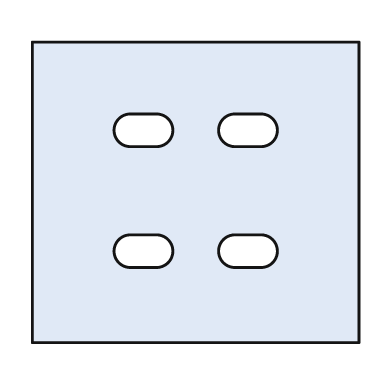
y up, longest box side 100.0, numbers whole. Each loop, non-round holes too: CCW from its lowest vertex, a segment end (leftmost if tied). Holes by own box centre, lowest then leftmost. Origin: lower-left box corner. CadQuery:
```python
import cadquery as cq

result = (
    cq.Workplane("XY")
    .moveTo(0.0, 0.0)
    .lineTo(100.0, 0.0)
    .lineTo(100.0, 92.0)
    .lineTo(0.0, 92.0)
    .close()
    .moveTo(30.0, 23.0)
    .lineTo(38.0, 23.0)
    .threePointArc((43.0, 28.0), (38.0, 33.0))
    .lineTo(30.0, 33.0)
    .threePointArc((25.0, 28.0), (30.0, 23.0))
    .close()
    .moveTo(62.0, 23.0)
    .lineTo(70.0, 23.0)
    .threePointArc((75.0, 28.0), (70.0, 33.0))
    .lineTo(62.0, 33.0)
    .threePointArc((57.0, 28.0), (62.0, 23.0))
    .close()
    .moveTo(30.0, 60.0)
    .lineTo(38.0, 60.0)
    .threePointArc((43.0, 65.0), (38.0, 70.0))
    .lineTo(30.0, 70.0)
    .threePointArc((25.0, 65.0), (30.0, 60.0))
    .close()
    .moveTo(62.0, 60.0)
    .lineTo(70.0, 60.0)
    .threePointArc((75.0, 65.0), (70.0, 70.0))
    .lineTo(62.0, 70.0)
    .threePointArc((57.0, 65.0), (62.0, 60.0))
    .close()
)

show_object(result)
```